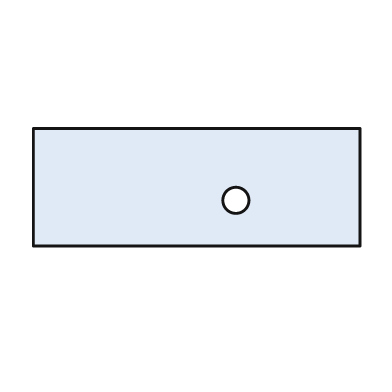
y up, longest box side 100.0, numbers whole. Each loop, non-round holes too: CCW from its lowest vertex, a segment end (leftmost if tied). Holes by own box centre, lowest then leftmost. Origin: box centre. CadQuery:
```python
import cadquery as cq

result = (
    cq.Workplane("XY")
    .moveTo(-50.0, -18.0)
    .lineTo(50.0, -18.0)
    .lineTo(50.0, 18.0)
    .lineTo(-50.0, 18.0)
    .close()
    .moveTo(12.0, -4.0)
    .circle(4.0)
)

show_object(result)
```